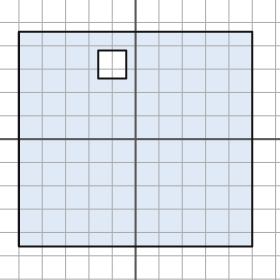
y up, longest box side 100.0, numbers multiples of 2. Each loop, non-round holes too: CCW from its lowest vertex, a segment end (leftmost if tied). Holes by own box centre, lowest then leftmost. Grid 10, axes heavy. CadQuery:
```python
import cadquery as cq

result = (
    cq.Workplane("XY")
    .moveTo(-50.0, -46.0)
    .lineTo(50.0, -46.0)
    .lineTo(50.0, 46.0)
    .lineTo(-50.0, 46.0)
    .close()
    .moveTo(-16.0, 26.0)
    .lineTo(-4.0, 26.0)
    .lineTo(-4.0, 38.0)
    .lineTo(-16.0, 38.0)
    .close()
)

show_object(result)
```